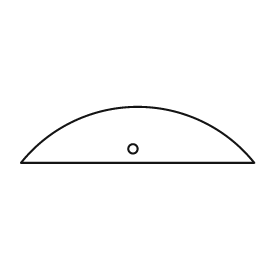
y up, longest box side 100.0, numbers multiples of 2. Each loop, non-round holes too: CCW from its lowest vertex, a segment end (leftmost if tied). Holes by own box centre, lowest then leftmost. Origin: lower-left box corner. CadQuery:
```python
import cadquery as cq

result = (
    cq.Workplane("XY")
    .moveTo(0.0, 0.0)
    .lineTo(100.0, 0.0)
    .threePointArc((50.0, 24.0), (0.0, 0.0))
    .close()
    .moveTo(48.0, 6.0)
    .circle(2.0)
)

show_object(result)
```